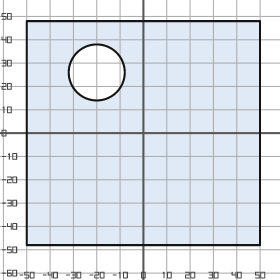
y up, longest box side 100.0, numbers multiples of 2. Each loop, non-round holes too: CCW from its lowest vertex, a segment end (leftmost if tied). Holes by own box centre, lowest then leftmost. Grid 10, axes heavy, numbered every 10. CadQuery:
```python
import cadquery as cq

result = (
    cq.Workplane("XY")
    .moveTo(-50.0, -48.0)
    .lineTo(50.0, -48.0)
    .lineTo(50.0, 48.0)
    .lineTo(-50.0, 48.0)
    .close()
    .moveTo(-20.0, 26.0)
    .circle(12.0)
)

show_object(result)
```